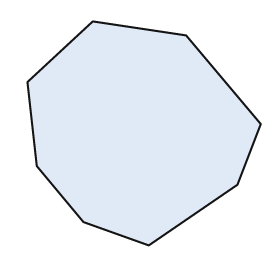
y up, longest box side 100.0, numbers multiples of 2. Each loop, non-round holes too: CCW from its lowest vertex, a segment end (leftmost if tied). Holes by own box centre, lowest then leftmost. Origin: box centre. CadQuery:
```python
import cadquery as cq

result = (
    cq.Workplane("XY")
    .moveTo(2.0, -48.0)
    .lineTo(40.0, -22.0)
    .lineTo(50.0, 4.0)
    .lineTo(18.0, 42.0)
    .lineTo(-22.0, 48.0)
    .lineTo(-50.0, 22.0)
    .lineTo(-46.0, -14.0)
    .lineTo(-26.0, -38.0)
    .close()
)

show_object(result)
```